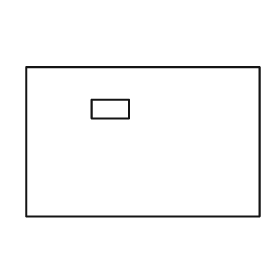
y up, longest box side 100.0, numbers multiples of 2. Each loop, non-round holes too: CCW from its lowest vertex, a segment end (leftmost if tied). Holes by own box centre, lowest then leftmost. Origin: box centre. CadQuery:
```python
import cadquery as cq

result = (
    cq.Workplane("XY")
    .moveTo(-50.0, -32.0)
    .lineTo(50.0, -32.0)
    .lineTo(50.0, 32.0)
    .lineTo(-50.0, 32.0)
    .close()
    .moveTo(-22.0, 10.0)
    .lineTo(-6.0, 10.0)
    .lineTo(-6.0, 18.0)
    .lineTo(-22.0, 18.0)
    .close()
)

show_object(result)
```